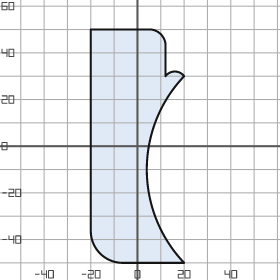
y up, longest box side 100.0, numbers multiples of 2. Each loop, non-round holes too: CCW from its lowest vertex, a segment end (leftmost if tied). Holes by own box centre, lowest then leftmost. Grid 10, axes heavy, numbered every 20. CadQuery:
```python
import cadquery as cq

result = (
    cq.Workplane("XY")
    .moveTo(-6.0, -50.0)
    .lineTo(20.0, -50.0)
    .threePointArc((4.0, -10.0), (20.0, 30.0))
    .threePointArc((16.0, 32.0), (12.0, 30.0))
    .lineTo(12.0, 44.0)
    .threePointArc((10.0, 48.0), (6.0, 50.0))
    .lineTo(-20.0, 50.0)
    .lineTo(-20.0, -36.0)
    .threePointArc((-16.0, -46.0), (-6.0, -50.0))
    .close()
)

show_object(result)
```